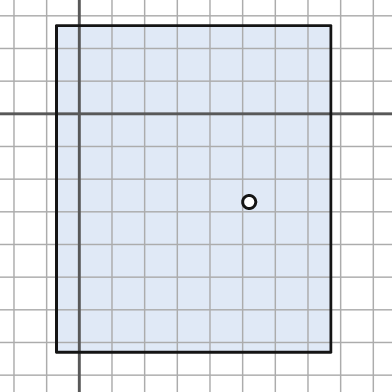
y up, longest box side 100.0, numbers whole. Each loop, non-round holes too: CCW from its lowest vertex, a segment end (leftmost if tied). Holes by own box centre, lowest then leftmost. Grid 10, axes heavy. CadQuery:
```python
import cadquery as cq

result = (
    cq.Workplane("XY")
    .moveTo(-7.0, -73.0)
    .lineTo(77.0, -73.0)
    .lineTo(77.0, 27.0)
    .lineTo(-7.0, 27.0)
    .close()
    .moveTo(52.0, -27.0)
    .circle(2.0)
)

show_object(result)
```